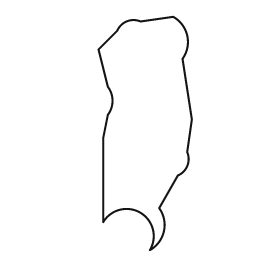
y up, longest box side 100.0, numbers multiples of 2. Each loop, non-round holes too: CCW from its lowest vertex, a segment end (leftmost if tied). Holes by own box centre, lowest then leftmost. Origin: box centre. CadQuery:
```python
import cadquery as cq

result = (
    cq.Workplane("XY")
    .moveTo(2.0, -50.0)
    .threePointArc((8.0, -42.0), (6.0, -32.0))
    .lineTo(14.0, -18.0)
    .threePointArc((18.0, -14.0), (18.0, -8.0))
    .lineTo(20.0, 6.0)
    .lineTo(16.0, 32.0)
    .threePointArc((18.0, 42.0), (12.0, 50.0))
    .lineTo(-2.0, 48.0)
    .threePointArc((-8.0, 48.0), (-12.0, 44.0))
    .lineTo(-20.0, 36.0)
    .lineTo(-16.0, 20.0)
    .threePointArc((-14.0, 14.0), (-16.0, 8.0))
    .lineTo(-18.0, -2.0)
    .lineTo(-18.0, -38.0)
    .threePointArc((-2.0, -34.0), (2.0, -50.0))
    .close()
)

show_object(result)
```